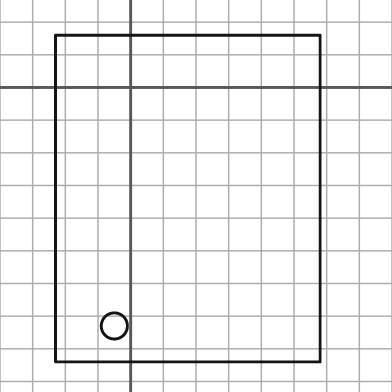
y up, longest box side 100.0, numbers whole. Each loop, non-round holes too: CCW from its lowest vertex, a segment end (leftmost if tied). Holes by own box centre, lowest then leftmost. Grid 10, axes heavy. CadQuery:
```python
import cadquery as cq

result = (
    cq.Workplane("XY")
    .moveTo(-23.0, -84.0)
    .lineTo(58.0, -84.0)
    .lineTo(58.0, 16.0)
    .lineTo(-23.0, 16.0)
    .close()
    .moveTo(-5.0, -73.0)
    .circle(4.0)
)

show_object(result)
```